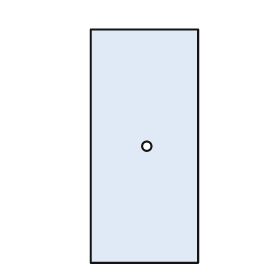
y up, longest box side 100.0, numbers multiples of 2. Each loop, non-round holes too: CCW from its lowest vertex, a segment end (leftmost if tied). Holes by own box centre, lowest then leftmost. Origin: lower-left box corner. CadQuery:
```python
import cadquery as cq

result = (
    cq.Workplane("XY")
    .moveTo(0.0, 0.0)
    .lineTo(46.0, 0.0)
    .lineTo(46.0, 100.0)
    .lineTo(0.0, 100.0)
    .close()
    .moveTo(24.0, 50.0)
    .circle(2.0)
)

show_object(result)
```